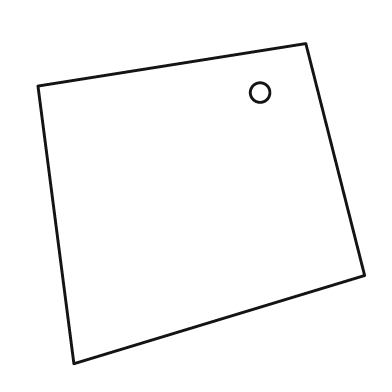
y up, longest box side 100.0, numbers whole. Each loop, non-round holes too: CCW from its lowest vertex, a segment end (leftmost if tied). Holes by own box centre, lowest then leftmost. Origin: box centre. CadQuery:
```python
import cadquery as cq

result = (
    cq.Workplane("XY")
    .moveTo(-39.0, -49.0)
    .lineTo(50.0, -22.0)
    .lineTo(32.0, 49.0)
    .lineTo(-50.0, 36.0)
    .close()
    .moveTo(18.0, 34.0)
    .circle(3.0)
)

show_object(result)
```